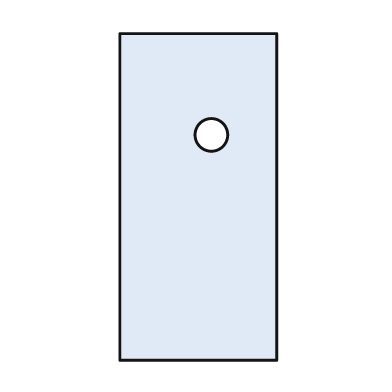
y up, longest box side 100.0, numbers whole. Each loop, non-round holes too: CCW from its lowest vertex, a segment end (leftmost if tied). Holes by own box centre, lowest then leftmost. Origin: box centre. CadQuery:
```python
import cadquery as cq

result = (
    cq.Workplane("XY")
    .moveTo(-24.0, -50.0)
    .lineTo(24.0, -50.0)
    .lineTo(24.0, 50.0)
    .lineTo(-24.0, 50.0)
    .close()
    .moveTo(4.0, 19.0)
    .circle(5.0)
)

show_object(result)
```